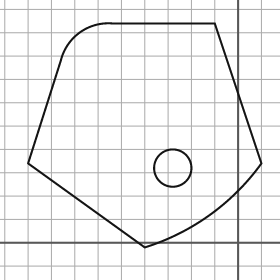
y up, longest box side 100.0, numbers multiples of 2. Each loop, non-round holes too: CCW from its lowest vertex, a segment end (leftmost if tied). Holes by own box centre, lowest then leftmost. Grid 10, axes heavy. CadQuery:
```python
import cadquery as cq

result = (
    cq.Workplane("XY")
    .moveTo(-40.0, -2.0)
    .threePointArc((-12.0, 12.0), (10.0, 34.0))
    .lineTo(-10.0, 94.0)
    .lineTo(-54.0, 94.0)
    .threePointArc((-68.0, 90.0), (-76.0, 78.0))
    .lineTo(-90.0, 34.0)
    .close()
    .moveTo(-28.0, 32.0)
    .circle(8.0)
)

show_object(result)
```